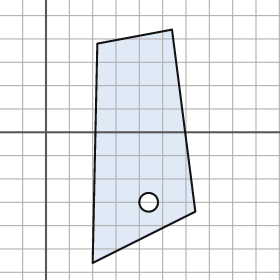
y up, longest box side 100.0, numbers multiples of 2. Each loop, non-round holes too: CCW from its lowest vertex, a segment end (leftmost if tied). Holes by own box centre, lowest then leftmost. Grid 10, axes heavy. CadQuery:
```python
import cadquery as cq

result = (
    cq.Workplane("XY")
    .moveTo(20.0, -56.0)
    .lineTo(64.0, -34.0)
    .lineTo(54.0, 44.0)
    .lineTo(22.0, 38.0)
    .close()
    .moveTo(44.0, -30.0)
    .circle(4.0)
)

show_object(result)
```